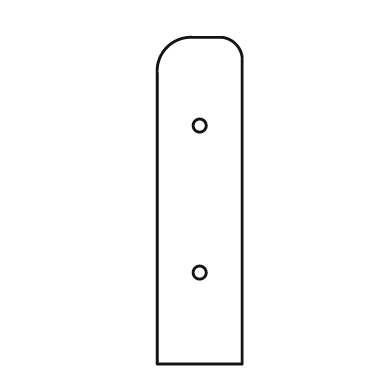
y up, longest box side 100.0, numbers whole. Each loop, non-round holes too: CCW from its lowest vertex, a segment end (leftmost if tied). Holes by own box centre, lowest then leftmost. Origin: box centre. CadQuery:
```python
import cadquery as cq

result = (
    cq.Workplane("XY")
    .moveTo(-13.0, -50.0)
    .lineTo(13.0, -50.0)
    .lineTo(13.0, 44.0)
    .threePointArc((11.0, 48.0), (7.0, 50.0))
    .lineTo(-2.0, 50.0)
    .threePointArc((-10.0, 47.0), (-13.0, 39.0))
    .close()
    .moveTo(0.0, -22.0)
    .circle(2.0)
    .moveTo(0.0, 23.0)
    .circle(2.0)
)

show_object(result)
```